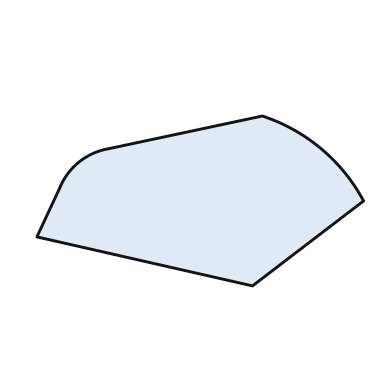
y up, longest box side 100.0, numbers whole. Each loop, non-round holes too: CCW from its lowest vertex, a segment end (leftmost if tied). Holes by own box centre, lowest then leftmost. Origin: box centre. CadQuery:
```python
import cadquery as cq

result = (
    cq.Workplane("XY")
    .moveTo(16.0, -26.0)
    .lineTo(50.0, 0.0)
    .threePointArc((37.0, 16.0), (19.0, 26.0))
    .lineTo(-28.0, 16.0)
    .threePointArc((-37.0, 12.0), (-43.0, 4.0))
    .lineTo(-50.0, -11.0)
    .close()
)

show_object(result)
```